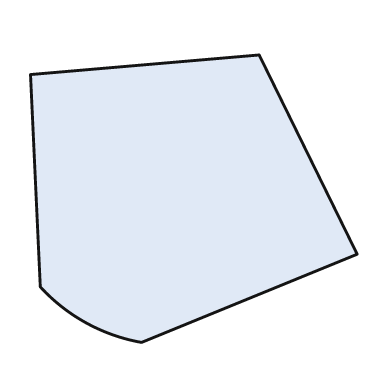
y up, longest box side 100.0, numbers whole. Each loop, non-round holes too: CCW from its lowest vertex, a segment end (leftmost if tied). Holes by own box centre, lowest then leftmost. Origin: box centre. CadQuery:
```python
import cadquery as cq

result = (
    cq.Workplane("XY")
    .moveTo(-16.0, -44.0)
    .lineTo(50.0, -17.0)
    .lineTo(20.0, 44.0)
    .lineTo(-50.0, 38.0)
    .lineTo(-47.0, -27.0)
    .threePointArc((-33.0, -38.0), (-16.0, -44.0))
    .close()
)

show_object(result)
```